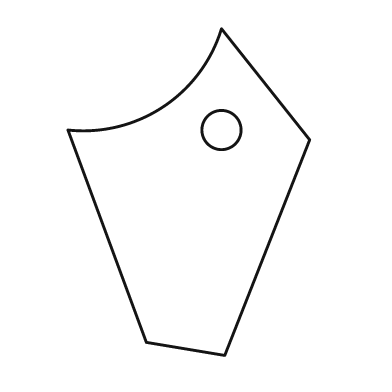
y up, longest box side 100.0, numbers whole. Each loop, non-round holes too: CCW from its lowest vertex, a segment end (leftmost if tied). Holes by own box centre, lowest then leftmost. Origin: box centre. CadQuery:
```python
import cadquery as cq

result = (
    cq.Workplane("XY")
    .moveTo(11.0, -50.0)
    .lineTo(37.0, 16.0)
    .lineTo(10.0, 50.0)
    .threePointArc((-8.0, 26.0), (-37.0, 19.0))
    .lineTo(-13.0, -46.0)
    .close()
    .moveTo(10.0, 19.0)
    .circle(6.0)
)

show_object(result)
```